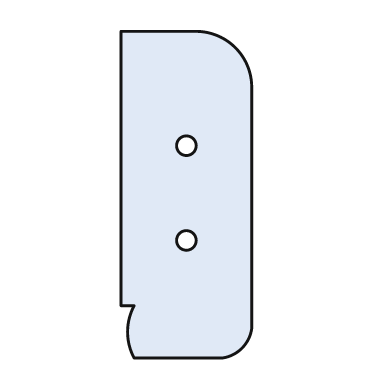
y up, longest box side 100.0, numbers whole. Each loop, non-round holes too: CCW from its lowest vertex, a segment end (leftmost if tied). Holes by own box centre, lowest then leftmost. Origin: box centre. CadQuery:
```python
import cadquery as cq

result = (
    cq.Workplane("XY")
    .moveTo(-16.0, -50.0)
    .lineTo(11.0, -50.0)
    .threePointArc((17.0, -47.0), (20.0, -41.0))
    .lineTo(20.0, 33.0)
    .threePointArc((15.0, 45.0), (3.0, 50.0))
    .lineTo(-20.0, 50.0)
    .lineTo(-20.0, -34.0)
    .lineTo(-16.0, -34.0)
    .threePointArc((-18.0, -42.0), (-16.0, -50.0))
    .close()
    .moveTo(0.0, -14.0)
    .circle(3.0)
    .moveTo(0.0, 15.0)
    .circle(3.0)
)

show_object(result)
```